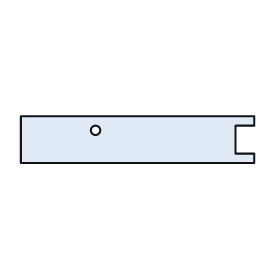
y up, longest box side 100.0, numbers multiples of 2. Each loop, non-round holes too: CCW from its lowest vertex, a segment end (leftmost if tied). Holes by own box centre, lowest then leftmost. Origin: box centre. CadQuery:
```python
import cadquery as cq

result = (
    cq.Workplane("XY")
    .moveTo(-50.0, -10.0)
    .lineTo(50.0, -10.0)
    .lineTo(50.0, -6.0)
    .lineTo(42.0, -6.0)
    .lineTo(42.0, 6.0)
    .lineTo(50.0, 6.0)
    .lineTo(50.0, 10.0)
    .lineTo(-50.0, 10.0)
    .close()
    .moveTo(-18.0, 4.0)
    .circle(2.0)
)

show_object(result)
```